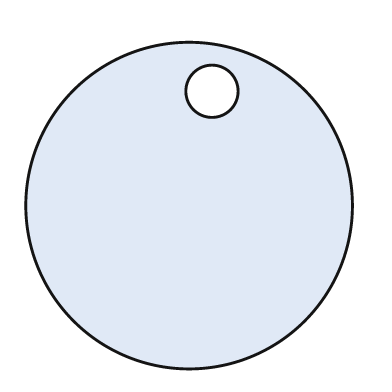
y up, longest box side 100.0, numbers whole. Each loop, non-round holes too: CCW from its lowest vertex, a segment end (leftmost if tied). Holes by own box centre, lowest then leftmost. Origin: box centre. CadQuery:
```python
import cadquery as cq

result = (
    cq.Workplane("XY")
    .moveTo(0.0, 0.0)
    .circle(50.0)
    .moveTo(7.0, 35.0)
    .circle(8.0)
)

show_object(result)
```